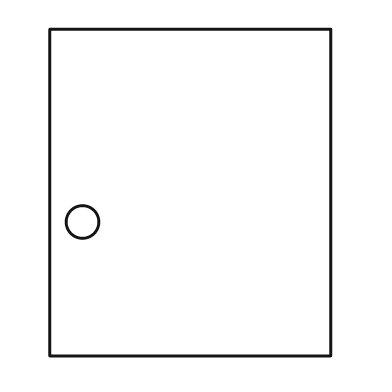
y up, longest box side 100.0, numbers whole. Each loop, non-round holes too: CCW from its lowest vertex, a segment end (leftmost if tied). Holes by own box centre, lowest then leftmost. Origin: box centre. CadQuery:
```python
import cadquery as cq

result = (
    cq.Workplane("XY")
    .moveTo(-43.0, -50.0)
    .lineTo(43.0, -50.0)
    .lineTo(43.0, 50.0)
    .lineTo(-43.0, 50.0)
    .close()
    .moveTo(-33.0, -9.0)
    .circle(5.0)
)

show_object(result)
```